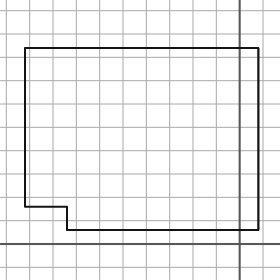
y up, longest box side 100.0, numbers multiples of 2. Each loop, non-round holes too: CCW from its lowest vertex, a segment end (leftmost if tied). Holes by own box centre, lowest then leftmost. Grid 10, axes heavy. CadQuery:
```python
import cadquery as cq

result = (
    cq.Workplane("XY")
    .moveTo(-74.0, 6.0)
    .lineTo(8.0, 6.0)
    .lineTo(8.0, 84.0)
    .lineTo(-92.0, 84.0)
    .lineTo(-92.0, 16.0)
    .lineTo(-74.0, 16.0)
    .close()
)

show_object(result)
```